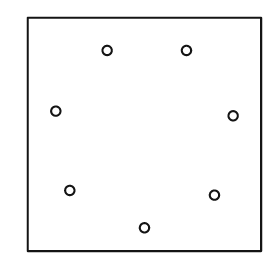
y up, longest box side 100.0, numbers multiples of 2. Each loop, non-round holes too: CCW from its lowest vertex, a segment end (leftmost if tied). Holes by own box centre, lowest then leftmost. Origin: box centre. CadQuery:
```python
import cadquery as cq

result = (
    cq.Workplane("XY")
    .moveTo(-50.0, -50.0)
    .lineTo(50.0, -50.0)
    .lineTo(50.0, 50.0)
    .lineTo(-50.0, 50.0)
    .close()
    .moveTo(0.0, -40.0)
    .circle(2.0)
    .moveTo(30.0, -26.0)
    .circle(2.0)
    .moveTo(-32.0, -24.0)
    .circle(2.0)
    .moveTo(38.0, 8.0)
    .circle(2.0)
    .moveTo(-38.0, 10.0)
    .circle(2.0)
    .moveTo(-16.0, 36.0)
    .circle(2.0)
    .moveTo(18.0, 36.0)
    .circle(2.0)
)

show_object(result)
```